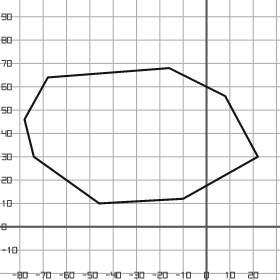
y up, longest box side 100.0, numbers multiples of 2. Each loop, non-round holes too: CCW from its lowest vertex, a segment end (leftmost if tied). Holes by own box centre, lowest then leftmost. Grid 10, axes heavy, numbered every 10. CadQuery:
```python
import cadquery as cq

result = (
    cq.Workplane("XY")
    .moveTo(-46.0, 10.0)
    .lineTo(-10.0, 12.0)
    .lineTo(22.0, 30.0)
    .lineTo(8.0, 56.0)
    .lineTo(-16.0, 68.0)
    .lineTo(-68.0, 64.0)
    .lineTo(-78.0, 46.0)
    .lineTo(-74.0, 30.0)
    .close()
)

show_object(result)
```